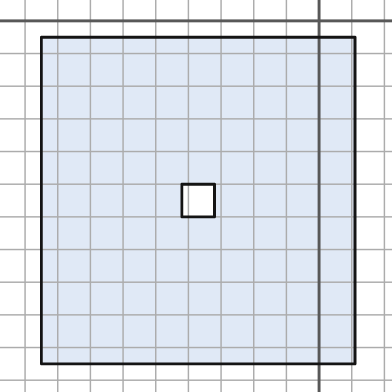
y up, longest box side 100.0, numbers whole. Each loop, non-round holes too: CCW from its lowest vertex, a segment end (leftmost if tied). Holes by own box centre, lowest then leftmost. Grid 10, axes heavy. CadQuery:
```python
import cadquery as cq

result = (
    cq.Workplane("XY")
    .moveTo(-85.0, -105.0)
    .lineTo(11.0, -105.0)
    .lineTo(11.0, -5.0)
    .lineTo(-85.0, -5.0)
    .close()
    .moveTo(-42.0, -60.0)
    .lineTo(-32.0, -60.0)
    .lineTo(-32.0, -50.0)
    .lineTo(-42.0, -50.0)
    .close()
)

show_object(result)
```